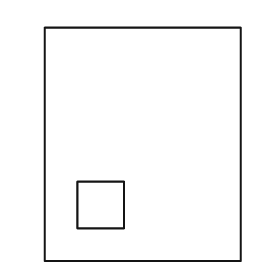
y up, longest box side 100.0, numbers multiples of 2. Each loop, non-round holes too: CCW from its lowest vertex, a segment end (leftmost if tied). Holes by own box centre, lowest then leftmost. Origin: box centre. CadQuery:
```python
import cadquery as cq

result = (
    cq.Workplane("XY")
    .moveTo(-42.0, -50.0)
    .lineTo(42.0, -50.0)
    .lineTo(42.0, 50.0)
    .lineTo(-42.0, 50.0)
    .close()
    .moveTo(-28.0, -36.0)
    .lineTo(-8.0, -36.0)
    .lineTo(-8.0, -16.0)
    .lineTo(-28.0, -16.0)
    .close()
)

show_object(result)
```